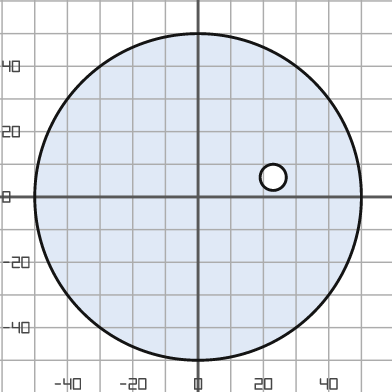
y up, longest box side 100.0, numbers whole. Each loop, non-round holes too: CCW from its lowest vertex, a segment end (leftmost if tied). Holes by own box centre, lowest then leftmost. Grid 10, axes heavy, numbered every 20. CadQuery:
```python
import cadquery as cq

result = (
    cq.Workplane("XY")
    .moveTo(0.0, 0.0)
    .circle(50.0)
    .moveTo(23.0, 6.0)
    .circle(4.0)
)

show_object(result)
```